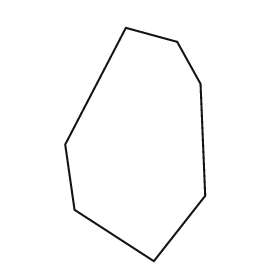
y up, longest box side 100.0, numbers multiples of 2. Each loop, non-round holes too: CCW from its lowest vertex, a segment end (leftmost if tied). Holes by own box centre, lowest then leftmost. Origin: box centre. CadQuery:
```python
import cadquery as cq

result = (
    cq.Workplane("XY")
    .moveTo(8.0, -50.0)
    .lineTo(30.0, -22.0)
    .lineTo(28.0, 26.0)
    .lineTo(18.0, 44.0)
    .lineTo(-4.0, 50.0)
    .lineTo(-30.0, 0.0)
    .lineTo(-26.0, -28.0)
    .close()
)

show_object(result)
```